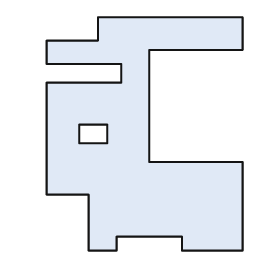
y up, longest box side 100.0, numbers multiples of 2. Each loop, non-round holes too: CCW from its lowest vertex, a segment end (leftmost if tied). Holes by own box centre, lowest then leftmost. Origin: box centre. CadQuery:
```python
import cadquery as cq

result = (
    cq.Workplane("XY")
    .moveTo(-24.0, -50.0)
    .lineTo(-12.0, -50.0)
    .lineTo(-12.0, -44.0)
    .lineTo(16.0, -44.0)
    .lineTo(16.0, -50.0)
    .lineTo(42.0, -50.0)
    .lineTo(42.0, -12.0)
    .lineTo(2.0, -12.0)
    .lineTo(2.0, 36.0)
    .lineTo(42.0, 36.0)
    .lineTo(42.0, 50.0)
    .lineTo(-20.0, 50.0)
    .lineTo(-20.0, 40.0)
    .lineTo(-42.0, 40.0)
    .lineTo(-42.0, 30.0)
    .lineTo(-10.0, 30.0)
    .lineTo(-10.0, 22.0)
    .lineTo(-42.0, 22.0)
    .lineTo(-42.0, -26.0)
    .lineTo(-24.0, -26.0)
    .close()
    .moveTo(-28.0, -4.0)
    .lineTo(-16.0, -4.0)
    .lineTo(-16.0, 4.0)
    .lineTo(-28.0, 4.0)
    .close()
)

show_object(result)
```